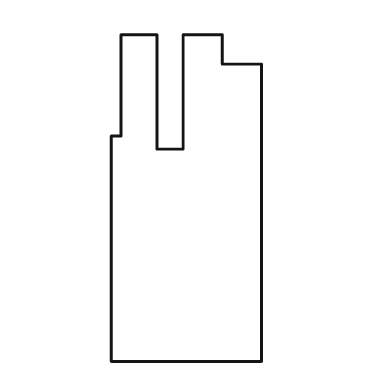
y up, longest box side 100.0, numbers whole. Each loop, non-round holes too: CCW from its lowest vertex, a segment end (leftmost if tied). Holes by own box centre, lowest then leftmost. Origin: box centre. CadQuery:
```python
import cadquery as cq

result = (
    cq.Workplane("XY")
    .moveTo(-23.0, -50.0)
    .lineTo(23.0, -50.0)
    .lineTo(23.0, 41.0)
    .lineTo(11.0, 41.0)
    .lineTo(11.0, 50.0)
    .lineTo(-1.0, 50.0)
    .lineTo(-1.0, 15.0)
    .lineTo(-9.0, 15.0)
    .lineTo(-9.0, 50.0)
    .lineTo(-20.0, 50.0)
    .lineTo(-20.0, 19.0)
    .lineTo(-23.0, 19.0)
    .close()
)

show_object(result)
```